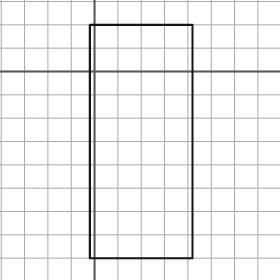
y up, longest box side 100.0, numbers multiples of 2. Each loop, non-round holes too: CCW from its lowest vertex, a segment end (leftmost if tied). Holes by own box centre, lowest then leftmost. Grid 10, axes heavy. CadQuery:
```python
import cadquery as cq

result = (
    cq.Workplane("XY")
    .moveTo(-2.0, -80.0)
    .lineTo(42.0, -80.0)
    .lineTo(42.0, 20.0)
    .lineTo(-2.0, 20.0)
    .close()
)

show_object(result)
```